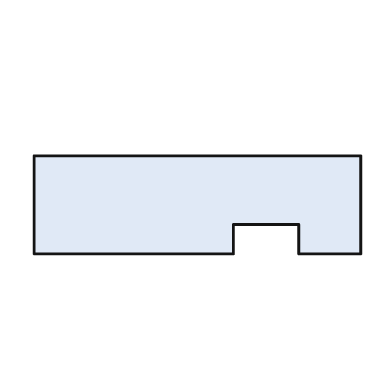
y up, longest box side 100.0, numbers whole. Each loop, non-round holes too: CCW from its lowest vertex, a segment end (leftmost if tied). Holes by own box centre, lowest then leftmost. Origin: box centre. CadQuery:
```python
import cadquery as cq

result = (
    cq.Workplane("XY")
    .moveTo(-50.0, -15.0)
    .lineTo(11.0, -15.0)
    .lineTo(11.0, -6.0)
    .lineTo(31.0, -6.0)
    .lineTo(31.0, -15.0)
    .lineTo(50.0, -15.0)
    .lineTo(50.0, 15.0)
    .lineTo(-50.0, 15.0)
    .close()
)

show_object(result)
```